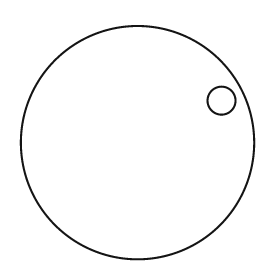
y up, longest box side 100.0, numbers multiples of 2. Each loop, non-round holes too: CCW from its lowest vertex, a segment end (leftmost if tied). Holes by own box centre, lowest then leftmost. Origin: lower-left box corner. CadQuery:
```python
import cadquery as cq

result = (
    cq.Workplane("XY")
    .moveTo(50.0, 50.0)
    .circle(50.0)
    .moveTo(86.0, 68.0)
    .circle(6.0)
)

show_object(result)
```